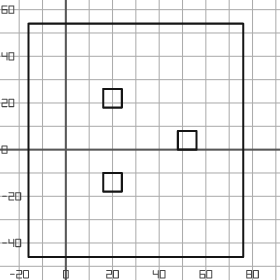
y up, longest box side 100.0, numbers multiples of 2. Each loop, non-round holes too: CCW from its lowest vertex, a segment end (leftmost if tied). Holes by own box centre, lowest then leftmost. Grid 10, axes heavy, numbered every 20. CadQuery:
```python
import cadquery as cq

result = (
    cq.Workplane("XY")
    .moveTo(-16.0, -46.0)
    .lineTo(76.0, -46.0)
    .lineTo(76.0, 54.0)
    .lineTo(-16.0, 54.0)
    .close()
    .moveTo(16.0, -18.0)
    .lineTo(24.0, -18.0)
    .lineTo(24.0, -10.0)
    .lineTo(16.0, -10.0)
    .close()
    .moveTo(48.0, 0.0)
    .lineTo(56.0, 0.0)
    .lineTo(56.0, 8.0)
    .lineTo(48.0, 8.0)
    .close()
    .moveTo(16.0, 18.0)
    .lineTo(24.0, 18.0)
    .lineTo(24.0, 26.0)
    .lineTo(16.0, 26.0)
    .close()
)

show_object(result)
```